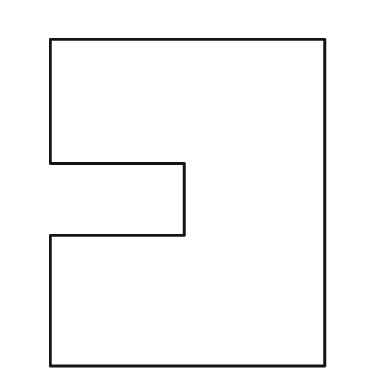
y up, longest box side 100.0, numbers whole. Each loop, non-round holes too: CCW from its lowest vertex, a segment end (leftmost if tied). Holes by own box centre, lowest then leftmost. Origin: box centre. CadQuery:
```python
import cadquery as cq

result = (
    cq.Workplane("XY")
    .moveTo(-42.0, -50.0)
    .lineTo(42.0, -50.0)
    .lineTo(42.0, 50.0)
    .lineTo(-42.0, 50.0)
    .lineTo(-42.0, 12.0)
    .lineTo(-1.0, 12.0)
    .lineTo(-1.0, -10.0)
    .lineTo(-42.0, -10.0)
    .close()
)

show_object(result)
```